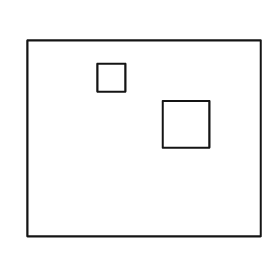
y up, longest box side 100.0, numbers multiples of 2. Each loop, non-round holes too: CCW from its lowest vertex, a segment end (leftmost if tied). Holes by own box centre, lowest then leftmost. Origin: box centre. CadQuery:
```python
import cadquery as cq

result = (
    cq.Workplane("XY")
    .moveTo(-50.0, -42.0)
    .lineTo(50.0, -42.0)
    .lineTo(50.0, 42.0)
    .lineTo(-50.0, 42.0)
    .close()
    .moveTo(8.0, -4.0)
    .lineTo(28.0, -4.0)
    .lineTo(28.0, 16.0)
    .lineTo(8.0, 16.0)
    .close()
    .moveTo(-20.0, 20.0)
    .lineTo(-8.0, 20.0)
    .lineTo(-8.0, 32.0)
    .lineTo(-20.0, 32.0)
    .close()
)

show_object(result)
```